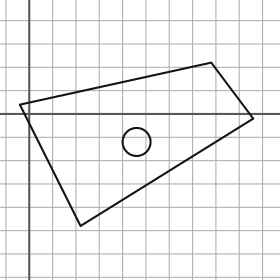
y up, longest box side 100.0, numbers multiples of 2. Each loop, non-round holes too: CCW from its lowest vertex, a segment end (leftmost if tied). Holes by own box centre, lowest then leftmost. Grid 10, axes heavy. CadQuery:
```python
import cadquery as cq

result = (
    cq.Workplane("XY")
    .moveTo(22.0, -48.0)
    .lineTo(96.0, -2.0)
    .lineTo(78.0, 22.0)
    .lineTo(-4.0, 4.0)
    .close()
    .moveTo(46.0, -12.0)
    .circle(6.0)
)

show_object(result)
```